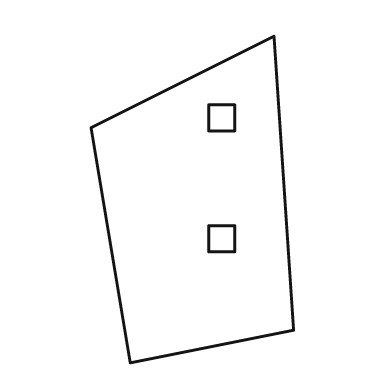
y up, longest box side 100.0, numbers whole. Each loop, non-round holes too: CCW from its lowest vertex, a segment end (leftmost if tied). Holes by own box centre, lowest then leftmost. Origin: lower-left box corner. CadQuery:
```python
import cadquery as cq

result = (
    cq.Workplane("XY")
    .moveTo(12.0, 0.0)
    .lineTo(62.0, 10.0)
    .lineTo(56.0, 100.0)
    .lineTo(0.0, 72.0)
    .close()
    .moveTo(36.0, 34.0)
    .lineTo(44.0, 34.0)
    .lineTo(44.0, 42.0)
    .lineTo(36.0, 42.0)
    .close()
    .moveTo(36.0, 71.0)
    .lineTo(44.0, 71.0)
    .lineTo(44.0, 79.0)
    .lineTo(36.0, 79.0)
    .close()
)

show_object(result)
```